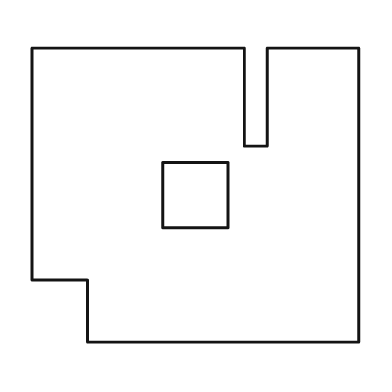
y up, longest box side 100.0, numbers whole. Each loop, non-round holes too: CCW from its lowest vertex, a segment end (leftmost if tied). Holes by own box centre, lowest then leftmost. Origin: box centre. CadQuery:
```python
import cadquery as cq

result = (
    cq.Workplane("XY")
    .moveTo(-33.0, -45.0)
    .lineTo(50.0, -45.0)
    .lineTo(50.0, 45.0)
    .lineTo(22.0, 45.0)
    .lineTo(22.0, 15.0)
    .lineTo(15.0, 15.0)
    .lineTo(15.0, 45.0)
    .lineTo(-50.0, 45.0)
    .lineTo(-50.0, -26.0)
    .lineTo(-33.0, -26.0)
    .close()
    .moveTo(-10.0, -10.0)
    .lineTo(10.0, -10.0)
    .lineTo(10.0, 10.0)
    .lineTo(-10.0, 10.0)
    .close()
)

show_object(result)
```